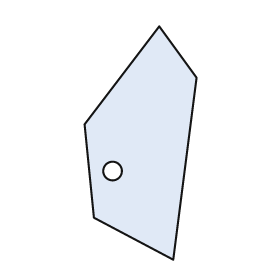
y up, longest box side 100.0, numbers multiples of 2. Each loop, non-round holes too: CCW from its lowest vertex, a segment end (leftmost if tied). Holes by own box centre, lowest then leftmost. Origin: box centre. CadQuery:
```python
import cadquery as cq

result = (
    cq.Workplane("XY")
    .moveTo(14.0, -50.0)
    .lineTo(24.0, 28.0)
    .lineTo(8.0, 50.0)
    .lineTo(-24.0, 8.0)
    .lineTo(-20.0, -32.0)
    .close()
    .moveTo(-12.0, -12.0)
    .circle(4.0)
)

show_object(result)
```